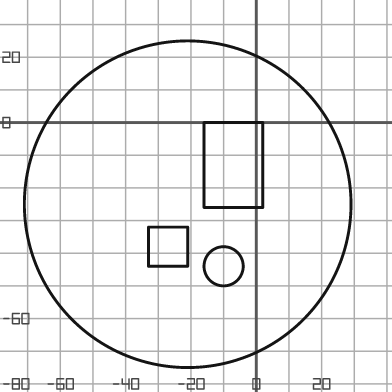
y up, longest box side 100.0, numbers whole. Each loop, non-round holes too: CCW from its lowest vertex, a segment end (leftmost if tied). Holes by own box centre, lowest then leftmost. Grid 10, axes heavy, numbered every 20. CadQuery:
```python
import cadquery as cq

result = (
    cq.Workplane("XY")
    .moveTo(-21.0, -25.0)
    .circle(50.0)
    .moveTo(-10.0, -44.0)
    .circle(6.0)
    .moveTo(-33.0, -44.0)
    .lineTo(-21.0, -44.0)
    .lineTo(-21.0, -32.0)
    .lineTo(-33.0, -32.0)
    .close()
    .moveTo(-16.0, -26.0)
    .lineTo(2.0, -26.0)
    .lineTo(2.0, 0.0)
    .lineTo(-16.0, 0.0)
    .close()
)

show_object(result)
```